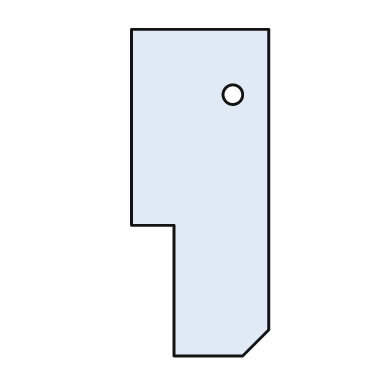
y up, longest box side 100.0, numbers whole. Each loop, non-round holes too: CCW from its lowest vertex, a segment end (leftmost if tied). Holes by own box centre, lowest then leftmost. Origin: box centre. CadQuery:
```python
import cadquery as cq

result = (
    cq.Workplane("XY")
    .moveTo(-8.0, -50.0)
    .lineTo(13.0, -50.0)
    .lineTo(21.0, -42.0)
    .lineTo(21.0, 50.0)
    .lineTo(-21.0, 50.0)
    .lineTo(-21.0, -10.0)
    .lineTo(-8.0, -10.0)
    .close()
    .moveTo(10.0, 30.0)
    .circle(3.0)
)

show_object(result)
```